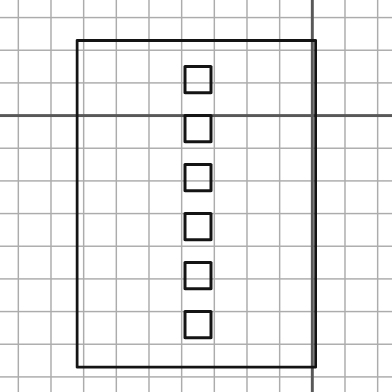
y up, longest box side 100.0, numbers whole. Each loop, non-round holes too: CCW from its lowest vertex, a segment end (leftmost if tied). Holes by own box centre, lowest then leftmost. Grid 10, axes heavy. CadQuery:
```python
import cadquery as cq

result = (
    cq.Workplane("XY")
    .moveTo(-72.0, -77.0)
    .lineTo(1.0, -77.0)
    .lineTo(1.0, 23.0)
    .lineTo(-72.0, 23.0)
    .close()
    .moveTo(-39.0, -68.0)
    .lineTo(-31.0, -68.0)
    .lineTo(-31.0, -60.0)
    .lineTo(-39.0, -60.0)
    .close()
    .moveTo(-39.0, -53.0)
    .lineTo(-31.0, -53.0)
    .lineTo(-31.0, -45.0)
    .lineTo(-39.0, -45.0)
    .close()
    .moveTo(-39.0, -38.0)
    .lineTo(-31.0, -38.0)
    .lineTo(-31.0, -30.0)
    .lineTo(-39.0, -30.0)
    .close()
    .moveTo(-39.0, -23.0)
    .lineTo(-31.0, -23.0)
    .lineTo(-31.0, -15.0)
    .lineTo(-39.0, -15.0)
    .close()
    .moveTo(-39.0, -8.0)
    .lineTo(-31.0, -8.0)
    .lineTo(-31.0, 0.0)
    .lineTo(-39.0, 0.0)
    .close()
    .moveTo(-39.0, 7.0)
    .lineTo(-31.0, 7.0)
    .lineTo(-31.0, 15.0)
    .lineTo(-39.0, 15.0)
    .close()
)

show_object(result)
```